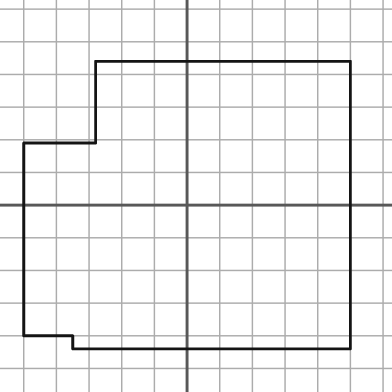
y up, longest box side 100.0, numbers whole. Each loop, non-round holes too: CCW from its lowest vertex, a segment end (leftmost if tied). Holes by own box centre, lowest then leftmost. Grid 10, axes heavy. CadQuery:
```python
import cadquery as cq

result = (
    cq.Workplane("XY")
    .moveTo(-35.0, -44.0)
    .lineTo(50.0, -44.0)
    .lineTo(50.0, 44.0)
    .lineTo(-28.0, 44.0)
    .lineTo(-28.0, 19.0)
    .lineTo(-50.0, 19.0)
    .lineTo(-50.0, -40.0)
    .lineTo(-35.0, -40.0)
    .close()
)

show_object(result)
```